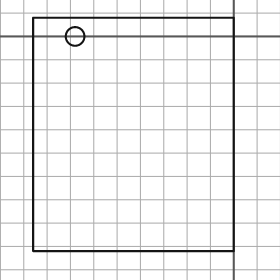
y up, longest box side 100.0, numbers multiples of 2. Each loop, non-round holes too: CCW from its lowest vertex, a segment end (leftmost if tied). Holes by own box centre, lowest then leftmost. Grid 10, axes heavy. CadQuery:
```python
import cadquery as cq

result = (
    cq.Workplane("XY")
    .moveTo(-86.0, -92.0)
    .lineTo(0.0, -92.0)
    .lineTo(0.0, 8.0)
    .lineTo(-86.0, 8.0)
    .close()
    .moveTo(-68.0, 0.0)
    .circle(4.0)
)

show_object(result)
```